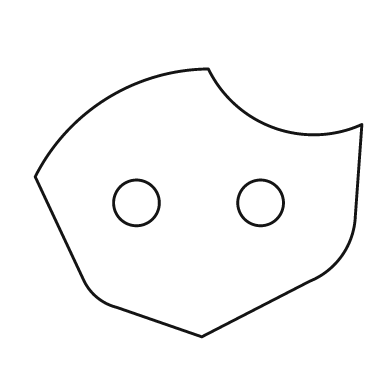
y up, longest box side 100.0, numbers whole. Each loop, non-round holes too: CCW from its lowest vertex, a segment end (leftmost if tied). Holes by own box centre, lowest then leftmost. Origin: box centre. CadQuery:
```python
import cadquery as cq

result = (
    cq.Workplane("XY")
    .moveTo(1.0, -41.0)
    .lineTo(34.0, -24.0)
    .threePointArc((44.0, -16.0), (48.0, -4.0))
    .lineTo(50.0, 24.0)
    .threePointArc((23.0, 23.0), (3.0, 41.0))
    .threePointArc((-28.0, 32.0), (-50.0, 8.0))
    .lineTo(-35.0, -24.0)
    .threePointArc((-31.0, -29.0), (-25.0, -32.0))
    .close()
    .moveTo(-19.0, 0.0)
    .circle(7.0)
    .moveTo(19.0, 0.0)
    .circle(7.0)
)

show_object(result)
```